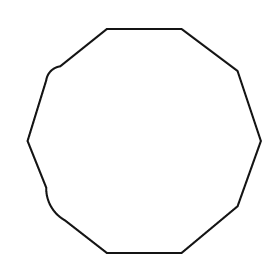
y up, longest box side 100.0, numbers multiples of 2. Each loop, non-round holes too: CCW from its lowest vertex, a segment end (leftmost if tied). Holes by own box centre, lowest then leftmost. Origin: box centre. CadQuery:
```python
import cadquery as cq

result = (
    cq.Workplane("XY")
    .moveTo(-16.0, -48.0)
    .lineTo(16.0, -48.0)
    .lineTo(40.0, -28.0)
    .lineTo(50.0, 0.0)
    .lineTo(40.0, 30.0)
    .lineTo(16.0, 48.0)
    .lineTo(-16.0, 48.0)
    .lineTo(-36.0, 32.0)
    .threePointArc((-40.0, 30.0), (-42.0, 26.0))
    .lineTo(-50.0, 0.0)
    .lineTo(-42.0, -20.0)
    .threePointArc((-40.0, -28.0), (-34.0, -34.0))
    .close()
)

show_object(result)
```